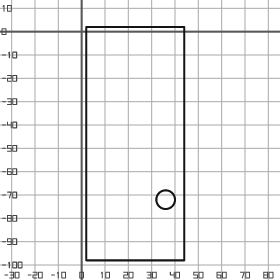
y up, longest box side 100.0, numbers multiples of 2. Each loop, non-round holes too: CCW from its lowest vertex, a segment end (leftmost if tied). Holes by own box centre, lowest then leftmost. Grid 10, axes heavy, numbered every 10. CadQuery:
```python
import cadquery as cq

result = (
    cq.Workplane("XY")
    .moveTo(2.0, -98.0)
    .lineTo(44.0, -98.0)
    .lineTo(44.0, 2.0)
    .lineTo(2.0, 2.0)
    .close()
    .moveTo(36.0, -72.0)
    .circle(4.0)
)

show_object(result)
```